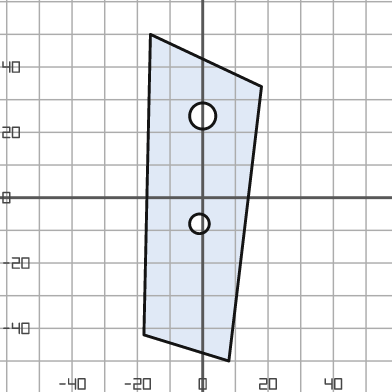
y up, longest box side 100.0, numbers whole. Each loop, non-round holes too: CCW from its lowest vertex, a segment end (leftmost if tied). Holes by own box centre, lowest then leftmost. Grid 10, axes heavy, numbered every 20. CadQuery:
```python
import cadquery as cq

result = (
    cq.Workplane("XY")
    .moveTo(8.0, -50.0)
    .lineTo(18.0, 34.0)
    .lineTo(-16.0, 50.0)
    .lineTo(-18.0, -42.0)
    .close()
    .moveTo(-1.0, -8.0)
    .circle(3.0)
    .moveTo(0.0, 25.0)
    .circle(4.0)
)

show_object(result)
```